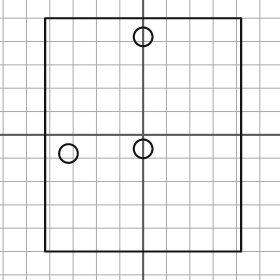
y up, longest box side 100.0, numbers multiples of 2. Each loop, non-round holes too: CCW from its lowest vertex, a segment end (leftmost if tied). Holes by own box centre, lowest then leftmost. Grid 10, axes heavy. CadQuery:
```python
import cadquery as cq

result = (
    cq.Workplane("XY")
    .moveTo(-42.0, -50.0)
    .lineTo(42.0, -50.0)
    .lineTo(42.0, 50.0)
    .lineTo(-42.0, 50.0)
    .close()
    .moveTo(-32.0, -8.0)
    .circle(4.0)
    .moveTo(0.0, -6.0)
    .circle(4.0)
    .moveTo(0.0, 42.0)
    .circle(4.0)
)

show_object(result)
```